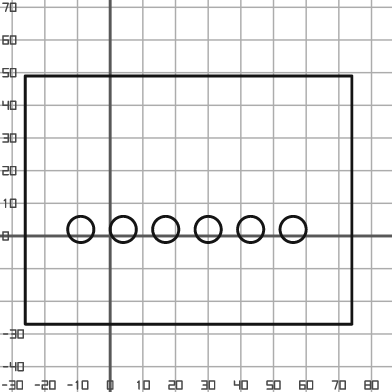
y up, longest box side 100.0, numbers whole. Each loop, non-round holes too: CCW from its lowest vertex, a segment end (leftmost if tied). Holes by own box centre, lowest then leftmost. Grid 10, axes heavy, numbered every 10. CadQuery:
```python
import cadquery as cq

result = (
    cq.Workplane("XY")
    .moveTo(-26.0, -27.0)
    .lineTo(74.0, -27.0)
    .lineTo(74.0, 49.0)
    .lineTo(-26.0, 49.0)
    .close()
    .moveTo(-9.0, 2.0)
    .circle(4.0)
    .moveTo(4.0, 2.0)
    .circle(4.0)
    .moveTo(17.0, 2.0)
    .circle(4.0)
    .moveTo(30.0, 2.0)
    .circle(4.0)
    .moveTo(43.0, 2.0)
    .circle(4.0)
    .moveTo(56.0, 2.0)
    .circle(4.0)
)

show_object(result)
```